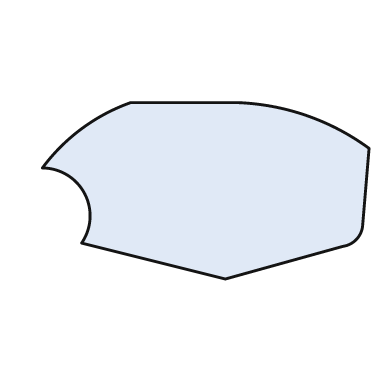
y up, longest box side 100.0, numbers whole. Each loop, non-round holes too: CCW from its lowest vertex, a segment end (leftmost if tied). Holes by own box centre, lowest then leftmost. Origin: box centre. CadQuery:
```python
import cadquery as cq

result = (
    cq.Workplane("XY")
    .moveTo(6.0, -27.0)
    .lineTo(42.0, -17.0)
    .threePointArc((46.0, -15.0), (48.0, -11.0))
    .lineTo(50.0, 13.0)
    .threePointArc((31.0, 23.0), (10.0, 27.0))
    .lineTo(-23.0, 27.0)
    .threePointArc((-38.0, 19.0), (-50.0, 7.0))
    .threePointArc((-37.0, -1.0), (-38.0, -16.0))
    .close()
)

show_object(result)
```